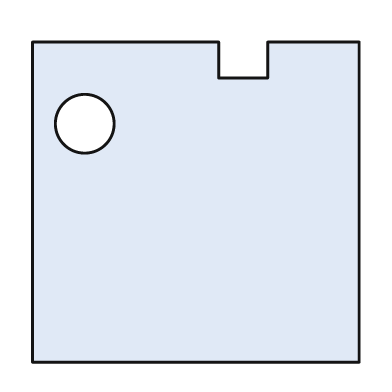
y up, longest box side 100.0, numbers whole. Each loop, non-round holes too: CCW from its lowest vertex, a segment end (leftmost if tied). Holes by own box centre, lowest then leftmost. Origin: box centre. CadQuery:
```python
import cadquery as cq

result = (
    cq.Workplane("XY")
    .moveTo(-50.0, -49.0)
    .lineTo(50.0, -49.0)
    .lineTo(50.0, 49.0)
    .lineTo(22.0, 49.0)
    .lineTo(22.0, 38.0)
    .lineTo(7.0, 38.0)
    .lineTo(7.0, 49.0)
    .lineTo(-50.0, 49.0)
    .close()
    .moveTo(-34.0, 24.0)
    .circle(9.0)
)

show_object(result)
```